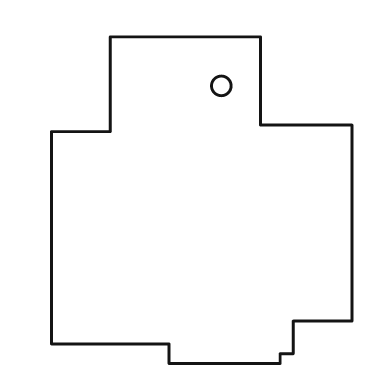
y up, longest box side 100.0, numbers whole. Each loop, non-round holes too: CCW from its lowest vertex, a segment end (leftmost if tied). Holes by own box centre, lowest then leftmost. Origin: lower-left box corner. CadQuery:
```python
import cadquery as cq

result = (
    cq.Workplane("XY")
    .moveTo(36.0, 0.0)
    .lineTo(70.0, 0.0)
    .lineTo(70.0, 3.0)
    .lineTo(74.0, 3.0)
    .lineTo(74.0, 13.0)
    .lineTo(92.0, 13.0)
    .lineTo(92.0, 73.0)
    .lineTo(64.0, 73.0)
    .lineTo(64.0, 100.0)
    .lineTo(18.0, 100.0)
    .lineTo(18.0, 71.0)
    .lineTo(0.0, 71.0)
    .lineTo(0.0, 6.0)
    .lineTo(36.0, 6.0)
    .close()
    .moveTo(52.0, 85.0)
    .circle(3.0)
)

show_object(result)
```